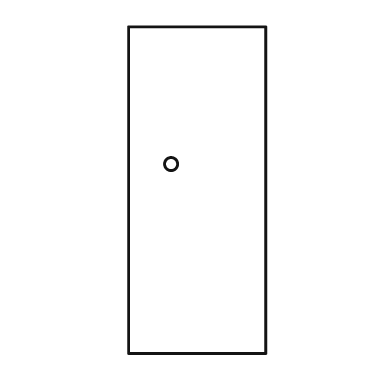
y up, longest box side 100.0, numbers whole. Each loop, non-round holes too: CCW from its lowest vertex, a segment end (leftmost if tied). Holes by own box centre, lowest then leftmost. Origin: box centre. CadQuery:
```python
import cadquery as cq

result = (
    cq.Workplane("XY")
    .moveTo(-21.0, -50.0)
    .lineTo(21.0, -50.0)
    .lineTo(21.0, 50.0)
    .lineTo(-21.0, 50.0)
    .close()
    .moveTo(-8.0, 8.0)
    .circle(2.0)
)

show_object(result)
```